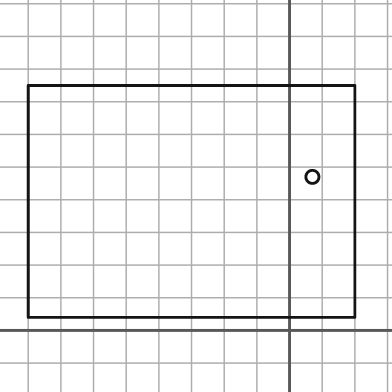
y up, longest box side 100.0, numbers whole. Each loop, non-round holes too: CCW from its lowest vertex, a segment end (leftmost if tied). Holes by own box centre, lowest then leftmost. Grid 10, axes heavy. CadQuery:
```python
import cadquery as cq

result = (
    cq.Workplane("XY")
    .moveTo(-80.0, 4.0)
    .lineTo(20.0, 4.0)
    .lineTo(20.0, 75.0)
    .lineTo(-80.0, 75.0)
    .close()
    .moveTo(7.0, 47.0)
    .circle(2.0)
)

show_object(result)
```